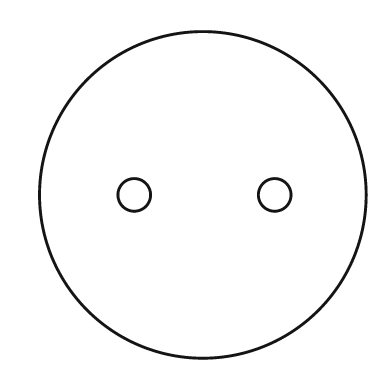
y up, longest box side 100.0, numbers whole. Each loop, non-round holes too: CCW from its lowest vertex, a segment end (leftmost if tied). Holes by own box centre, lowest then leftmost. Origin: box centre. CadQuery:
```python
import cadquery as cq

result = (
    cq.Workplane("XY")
    .moveTo(0.0, 0.0)
    .circle(50.0)
    .moveTo(-21.0, 0.0)
    .circle(5.0)
    .moveTo(22.0, 0.0)
    .circle(5.0)
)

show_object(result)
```